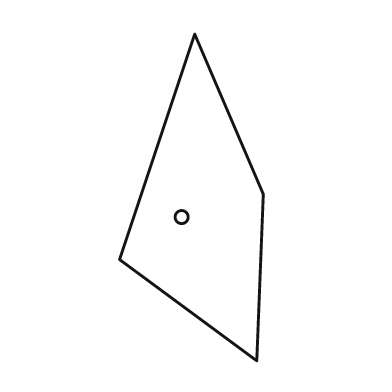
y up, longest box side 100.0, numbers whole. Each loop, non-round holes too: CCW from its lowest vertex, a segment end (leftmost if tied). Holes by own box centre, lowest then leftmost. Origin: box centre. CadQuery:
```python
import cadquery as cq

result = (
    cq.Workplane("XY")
    .moveTo(20.0, -50.0)
    .lineTo(22.0, 1.0)
    .lineTo(1.0, 50.0)
    .lineTo(-22.0, -19.0)
    .close()
    .moveTo(-3.0, -6.0)
    .circle(2.0)
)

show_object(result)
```